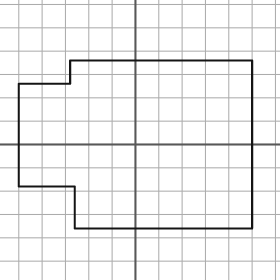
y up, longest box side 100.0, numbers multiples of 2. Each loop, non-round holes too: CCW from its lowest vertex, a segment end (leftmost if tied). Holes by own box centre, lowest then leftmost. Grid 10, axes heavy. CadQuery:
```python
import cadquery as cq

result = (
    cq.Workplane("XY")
    .moveTo(-26.0, -36.0)
    .lineTo(50.0, -36.0)
    .lineTo(50.0, 36.0)
    .lineTo(-28.0, 36.0)
    .lineTo(-28.0, 26.0)
    .lineTo(-50.0, 26.0)
    .lineTo(-50.0, -18.0)
    .lineTo(-26.0, -18.0)
    .close()
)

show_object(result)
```